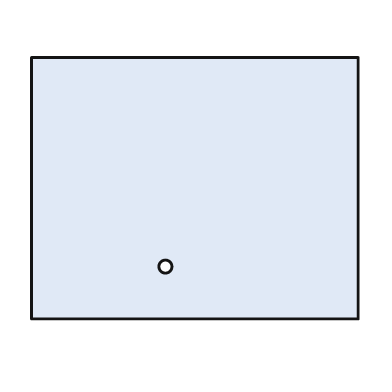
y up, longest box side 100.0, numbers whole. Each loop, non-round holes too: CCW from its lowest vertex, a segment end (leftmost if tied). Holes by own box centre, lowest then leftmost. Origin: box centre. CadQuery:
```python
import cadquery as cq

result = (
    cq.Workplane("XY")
    .moveTo(-50.0, -40.0)
    .lineTo(50.0, -40.0)
    .lineTo(50.0, 40.0)
    .lineTo(-50.0, 40.0)
    .close()
    .moveTo(-9.0, -24.0)
    .circle(2.0)
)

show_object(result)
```